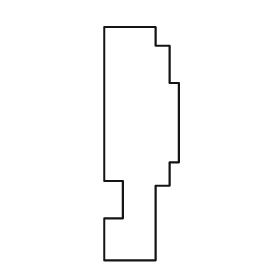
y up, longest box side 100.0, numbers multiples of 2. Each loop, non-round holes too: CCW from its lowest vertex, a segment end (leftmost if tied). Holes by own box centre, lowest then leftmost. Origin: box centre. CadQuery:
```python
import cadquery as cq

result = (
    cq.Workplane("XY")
    .moveTo(-16.0, -50.0)
    .lineTo(6.0, -50.0)
    .lineTo(6.0, -18.0)
    .lineTo(12.0, -18.0)
    .lineTo(12.0, -8.0)
    .lineTo(16.0, -8.0)
    .lineTo(16.0, 26.0)
    .lineTo(12.0, 26.0)
    .lineTo(12.0, 42.0)
    .lineTo(6.0, 42.0)
    .lineTo(6.0, 50.0)
    .lineTo(-16.0, 50.0)
    .lineTo(-16.0, -16.0)
    .lineTo(-8.0, -16.0)
    .lineTo(-8.0, -32.0)
    .lineTo(-16.0, -32.0)
    .close()
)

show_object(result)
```